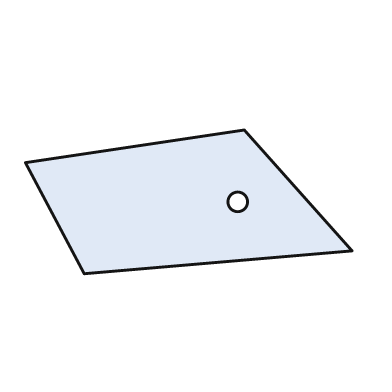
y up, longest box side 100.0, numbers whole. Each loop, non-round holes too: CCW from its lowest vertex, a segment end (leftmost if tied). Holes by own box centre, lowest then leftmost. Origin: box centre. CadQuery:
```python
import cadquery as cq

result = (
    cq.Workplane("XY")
    .moveTo(-32.0, -22.0)
    .lineTo(50.0, -15.0)
    .lineTo(17.0, 22.0)
    .lineTo(-50.0, 12.0)
    .close()
    .moveTo(15.0, 0.0)
    .circle(3.0)
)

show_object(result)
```